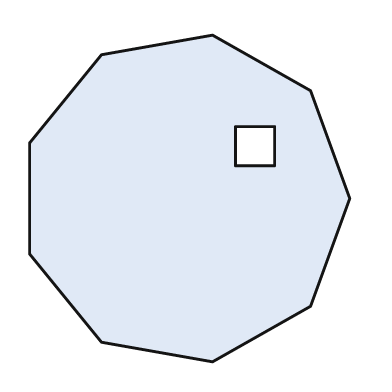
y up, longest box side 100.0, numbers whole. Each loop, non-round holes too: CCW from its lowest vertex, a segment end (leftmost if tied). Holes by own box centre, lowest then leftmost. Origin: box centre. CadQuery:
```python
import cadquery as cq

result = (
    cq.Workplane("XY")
    .moveTo(7.0, -50.0)
    .lineTo(37.0, -33.0)
    .lineTo(49.0, 0.0)
    .lineTo(37.0, 33.0)
    .lineTo(7.0, 50.0)
    .lineTo(-27.0, 44.0)
    .lineTo(-49.0, 17.0)
    .lineTo(-49.0, -17.0)
    .lineTo(-27.0, -44.0)
    .close()
    .moveTo(14.0, 10.0)
    .lineTo(26.0, 10.0)
    .lineTo(26.0, 22.0)
    .lineTo(14.0, 22.0)
    .close()
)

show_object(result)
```